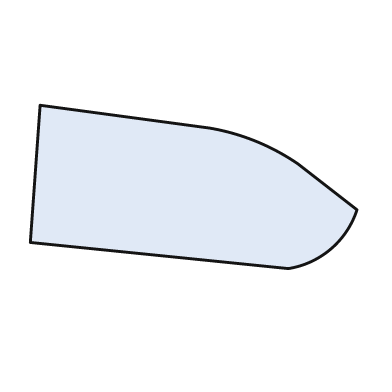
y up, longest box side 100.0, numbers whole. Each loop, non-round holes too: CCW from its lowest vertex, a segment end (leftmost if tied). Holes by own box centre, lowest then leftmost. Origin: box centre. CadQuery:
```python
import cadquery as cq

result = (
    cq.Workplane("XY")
    .moveTo(29.0, -25.0)
    .threePointArc((42.0, -19.0), (50.0, -7.0))
    .lineTo(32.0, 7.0)
    .threePointArc((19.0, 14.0), (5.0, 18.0))
    .lineTo(-47.0, 25.0)
    .lineTo(-50.0, -17.0)
    .close()
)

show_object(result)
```